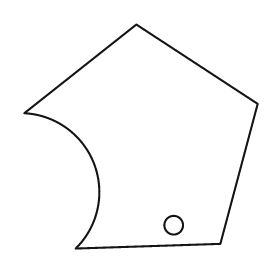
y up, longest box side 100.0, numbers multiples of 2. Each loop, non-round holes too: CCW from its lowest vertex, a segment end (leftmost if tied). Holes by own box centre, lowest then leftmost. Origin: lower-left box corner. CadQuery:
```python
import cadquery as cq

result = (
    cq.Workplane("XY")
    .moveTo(22.0, 0.0)
    .lineTo(84.0, 2.0)
    .lineTo(100.0, 62.0)
    .lineTo(48.0, 96.0)
    .lineTo(0.0, 58.0)
    .threePointArc((30.0, 36.0), (22.0, 0.0))
    .close()
    .moveTo(64.0, 10.0)
    .circle(4.0)
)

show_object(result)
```